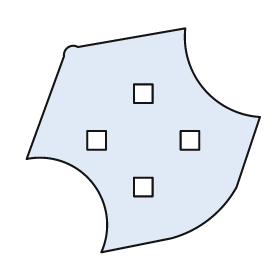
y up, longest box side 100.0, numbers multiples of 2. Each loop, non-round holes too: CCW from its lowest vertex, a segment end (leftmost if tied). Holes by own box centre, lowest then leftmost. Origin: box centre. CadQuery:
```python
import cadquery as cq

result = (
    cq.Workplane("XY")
    .moveTo(-18.0, -48.0)
    .lineTo(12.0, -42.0)
    .threePointArc((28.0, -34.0), (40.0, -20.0))
    .lineTo(50.0, 10.0)
    .threePointArc((26.0, 22.0), (18.0, 48.0))
    .lineTo(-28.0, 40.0)
    .threePointArc((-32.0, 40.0), (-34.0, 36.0))
    .lineTo(-50.0, -8.0)
    .threePointArc((-22.0, -18.0), (-18.0, -48.0))
    .close()
    .moveTo(-4.0, -24.0)
    .lineTo(4.0, -24.0)
    .lineTo(4.0, -16.0)
    .lineTo(-4.0, -16.0)
    .close()
    .moveTo(-24.0, -4.0)
    .lineTo(-16.0, -4.0)
    .lineTo(-16.0, 4.0)
    .lineTo(-24.0, 4.0)
    .close()
    .moveTo(16.0, -4.0)
    .lineTo(24.0, -4.0)
    .lineTo(24.0, 4.0)
    .lineTo(16.0, 4.0)
    .close()
    .moveTo(-4.0, 16.0)
    .lineTo(4.0, 16.0)
    .lineTo(4.0, 24.0)
    .lineTo(-4.0, 24.0)
    .close()
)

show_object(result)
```